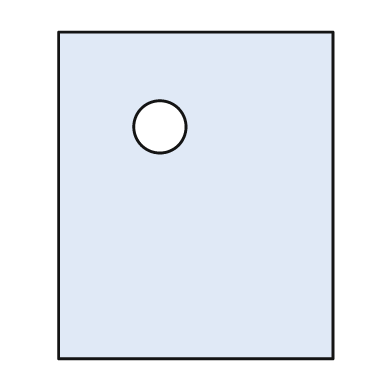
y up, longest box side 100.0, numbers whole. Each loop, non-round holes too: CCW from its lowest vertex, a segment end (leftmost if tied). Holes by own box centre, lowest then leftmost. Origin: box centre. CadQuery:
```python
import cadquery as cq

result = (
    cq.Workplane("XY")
    .moveTo(-42.0, -50.0)
    .lineTo(42.0, -50.0)
    .lineTo(42.0, 50.0)
    .lineTo(-42.0, 50.0)
    .close()
    .moveTo(-11.0, 21.0)
    .circle(8.0)
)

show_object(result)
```